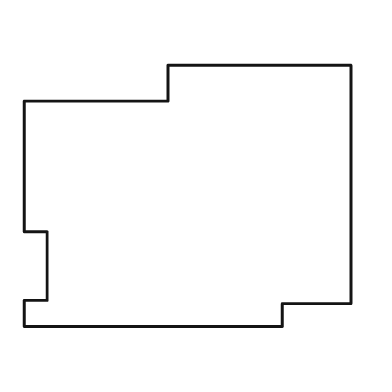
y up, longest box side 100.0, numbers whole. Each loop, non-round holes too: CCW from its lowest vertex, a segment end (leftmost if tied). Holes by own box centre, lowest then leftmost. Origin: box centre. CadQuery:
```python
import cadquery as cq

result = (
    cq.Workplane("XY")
    .moveTo(-50.0, -40.0)
    .lineTo(29.0, -40.0)
    .lineTo(29.0, -33.0)
    .lineTo(50.0, -33.0)
    .lineTo(50.0, 40.0)
    .lineTo(-6.0, 40.0)
    .lineTo(-6.0, 29.0)
    .lineTo(-50.0, 29.0)
    .lineTo(-50.0, -11.0)
    .lineTo(-43.0, -11.0)
    .lineTo(-43.0, -32.0)
    .lineTo(-50.0, -32.0)
    .close()
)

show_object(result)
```